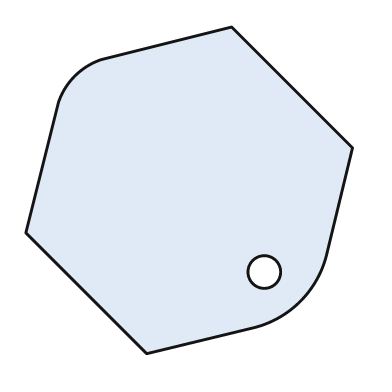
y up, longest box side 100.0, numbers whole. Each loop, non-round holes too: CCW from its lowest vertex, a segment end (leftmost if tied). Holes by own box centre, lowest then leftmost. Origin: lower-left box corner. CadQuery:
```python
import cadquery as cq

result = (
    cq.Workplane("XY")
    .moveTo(37.0, 0.0)
    .lineTo(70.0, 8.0)
    .threePointArc((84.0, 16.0), (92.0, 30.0))
    .lineTo(100.0, 63.0)
    .lineTo(63.0, 100.0)
    .lineTo(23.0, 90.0)
    .threePointArc((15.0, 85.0), (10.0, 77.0))
    .lineTo(0.0, 37.0)
    .close()
    .moveTo(73.0, 25.0)
    .circle(5.0)
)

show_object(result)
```